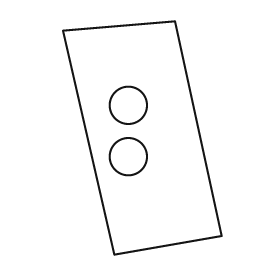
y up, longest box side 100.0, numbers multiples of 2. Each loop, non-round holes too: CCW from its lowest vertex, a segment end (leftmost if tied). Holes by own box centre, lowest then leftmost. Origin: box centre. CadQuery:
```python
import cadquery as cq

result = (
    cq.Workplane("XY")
    .moveTo(-12.0, -50.0)
    .lineTo(34.0, -42.0)
    .lineTo(14.0, 50.0)
    .lineTo(-34.0, 46.0)
    .close()
    .moveTo(-6.0, -8.0)
    .circle(8.0)
    .moveTo(-6.0, 14.0)
    .circle(8.0)
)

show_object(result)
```